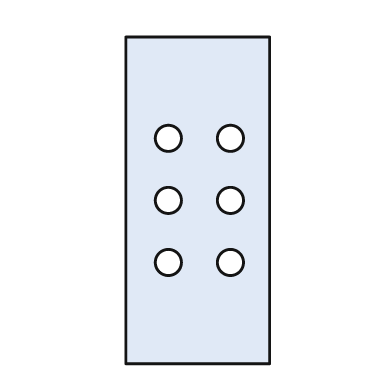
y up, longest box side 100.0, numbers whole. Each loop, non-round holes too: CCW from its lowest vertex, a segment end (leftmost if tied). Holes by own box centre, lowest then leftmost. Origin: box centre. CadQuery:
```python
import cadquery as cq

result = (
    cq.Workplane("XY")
    .moveTo(-22.0, -50.0)
    .lineTo(22.0, -50.0)
    .lineTo(22.0, 50.0)
    .lineTo(-22.0, 50.0)
    .close()
    .moveTo(-9.0, -19.0)
    .circle(4.0)
    .moveTo(10.0, -19.0)
    .circle(4.0)
    .moveTo(-9.0, 0.0)
    .circle(4.0)
    .moveTo(10.0, 0.0)
    .circle(4.0)
    .moveTo(-9.0, 19.0)
    .circle(4.0)
    .moveTo(10.0, 19.0)
    .circle(4.0)
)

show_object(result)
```